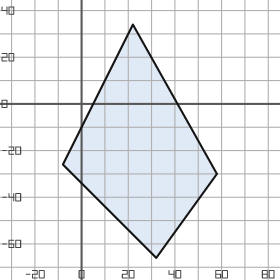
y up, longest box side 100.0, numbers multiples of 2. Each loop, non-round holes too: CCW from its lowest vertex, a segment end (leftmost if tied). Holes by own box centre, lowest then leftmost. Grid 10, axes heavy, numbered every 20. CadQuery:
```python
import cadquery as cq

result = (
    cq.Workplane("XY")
    .moveTo(32.0, -66.0)
    .lineTo(58.0, -30.0)
    .lineTo(22.0, 34.0)
    .lineTo(-8.0, -26.0)
    .close()
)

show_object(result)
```